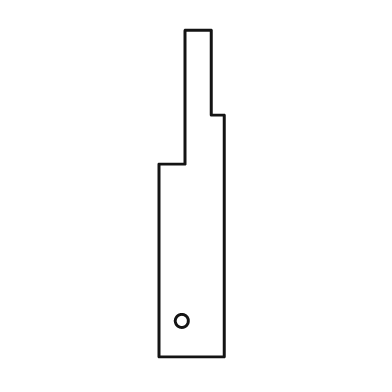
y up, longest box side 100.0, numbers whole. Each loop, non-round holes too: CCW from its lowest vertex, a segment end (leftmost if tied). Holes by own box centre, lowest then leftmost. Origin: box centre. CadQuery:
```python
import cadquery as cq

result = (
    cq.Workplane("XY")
    .moveTo(-10.0, -50.0)
    .lineTo(10.0, -50.0)
    .lineTo(10.0, 24.0)
    .lineTo(6.0, 24.0)
    .lineTo(6.0, 50.0)
    .lineTo(-2.0, 50.0)
    .lineTo(-2.0, 9.0)
    .lineTo(-10.0, 9.0)
    .close()
    .moveTo(-3.0, -39.0)
    .circle(2.0)
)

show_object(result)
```